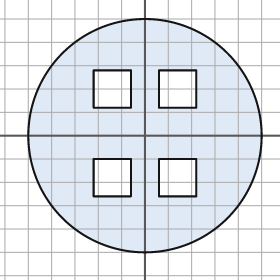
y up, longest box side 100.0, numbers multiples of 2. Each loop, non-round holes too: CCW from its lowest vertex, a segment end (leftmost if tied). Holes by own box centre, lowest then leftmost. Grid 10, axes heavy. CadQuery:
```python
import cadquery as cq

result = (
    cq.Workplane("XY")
    .moveTo(0.0, 0.0)
    .circle(50.0)
    .moveTo(-22.0, -26.0)
    .lineTo(-6.0, -26.0)
    .lineTo(-6.0, -10.0)
    .lineTo(-22.0, -10.0)
    .close()
    .moveTo(6.0, -26.0)
    .lineTo(22.0, -26.0)
    .lineTo(22.0, -10.0)
    .lineTo(6.0, -10.0)
    .close()
    .moveTo(-22.0, 12.0)
    .lineTo(-6.0, 12.0)
    .lineTo(-6.0, 28.0)
    .lineTo(-22.0, 28.0)
    .close()
    .moveTo(6.0, 12.0)
    .lineTo(22.0, 12.0)
    .lineTo(22.0, 28.0)
    .lineTo(6.0, 28.0)
    .close()
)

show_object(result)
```